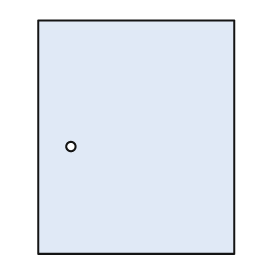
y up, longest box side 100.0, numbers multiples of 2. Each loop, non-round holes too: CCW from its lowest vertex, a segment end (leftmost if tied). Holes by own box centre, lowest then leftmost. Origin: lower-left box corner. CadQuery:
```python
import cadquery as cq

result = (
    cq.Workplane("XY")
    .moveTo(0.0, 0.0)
    .lineTo(84.0, 0.0)
    .lineTo(84.0, 100.0)
    .lineTo(0.0, 100.0)
    .close()
    .moveTo(14.0, 46.0)
    .circle(2.0)
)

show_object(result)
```